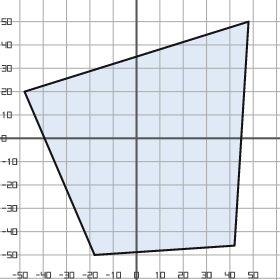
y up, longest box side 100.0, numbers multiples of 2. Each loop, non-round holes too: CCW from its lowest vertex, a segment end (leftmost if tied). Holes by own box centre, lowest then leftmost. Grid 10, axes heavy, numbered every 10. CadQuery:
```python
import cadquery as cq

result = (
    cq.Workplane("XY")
    .moveTo(-18.0, -50.0)
    .lineTo(42.0, -46.0)
    .lineTo(48.0, 50.0)
    .lineTo(-48.0, 20.0)
    .close()
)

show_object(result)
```